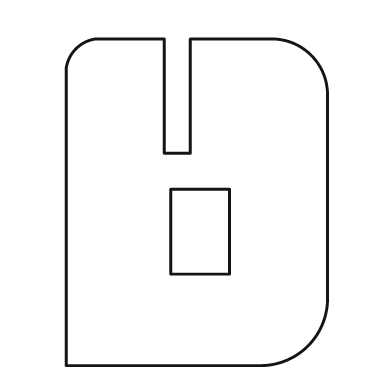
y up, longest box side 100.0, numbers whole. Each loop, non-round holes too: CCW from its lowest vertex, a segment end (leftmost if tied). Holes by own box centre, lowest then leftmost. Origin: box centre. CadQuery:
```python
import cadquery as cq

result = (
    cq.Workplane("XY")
    .moveTo(-40.0, -50.0)
    .lineTo(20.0, -50.0)
    .threePointArc((34.0, -44.0), (40.0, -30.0))
    .lineTo(40.0, 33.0)
    .threePointArc((35.0, 45.0), (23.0, 50.0))
    .lineTo(-2.0, 50.0)
    .lineTo(-2.0, 15.0)
    .lineTo(-10.0, 15.0)
    .lineTo(-10.0, 50.0)
    .lineTo(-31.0, 50.0)
    .threePointArc((-37.0, 47.0), (-40.0, 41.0))
    .close()
    .moveTo(-8.0, -22.0)
    .lineTo(10.0, -22.0)
    .lineTo(10.0, 4.0)
    .lineTo(-8.0, 4.0)
    .close()
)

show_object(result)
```